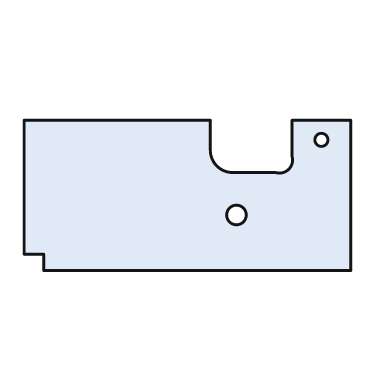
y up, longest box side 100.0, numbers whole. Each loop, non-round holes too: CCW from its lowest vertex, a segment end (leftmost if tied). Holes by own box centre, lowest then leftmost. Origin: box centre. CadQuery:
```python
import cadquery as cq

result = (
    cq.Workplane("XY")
    .moveTo(-44.0, -23.0)
    .lineTo(50.0, -23.0)
    .lineTo(50.0, 23.0)
    .lineTo(32.0, 23.0)
    .lineTo(32.0, 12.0)
    .threePointArc((31.0, 8.0), (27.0, 7.0))
    .lineTo(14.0, 7.0)
    .threePointArc((9.0, 9.0), (7.0, 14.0))
    .lineTo(7.0, 23.0)
    .lineTo(-50.0, 23.0)
    .lineTo(-50.0, -18.0)
    .lineTo(-44.0, -18.0)
    .close()
    .moveTo(15.0, -6.0)
    .circle(3.0)
    .moveTo(41.0, 17.0)
    .circle(2.0)
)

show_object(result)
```